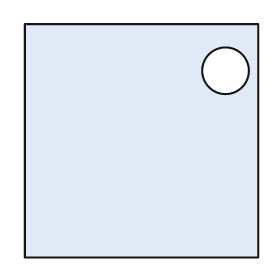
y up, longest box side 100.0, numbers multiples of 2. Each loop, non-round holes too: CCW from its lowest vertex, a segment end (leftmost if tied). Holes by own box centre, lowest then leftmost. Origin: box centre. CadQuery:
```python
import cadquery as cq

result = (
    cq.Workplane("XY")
    .moveTo(-50.0, -50.0)
    .lineTo(50.0, -50.0)
    .lineTo(50.0, 50.0)
    .lineTo(-50.0, 50.0)
    .close()
    .moveTo(36.0, 30.0)
    .circle(10.0)
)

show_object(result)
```